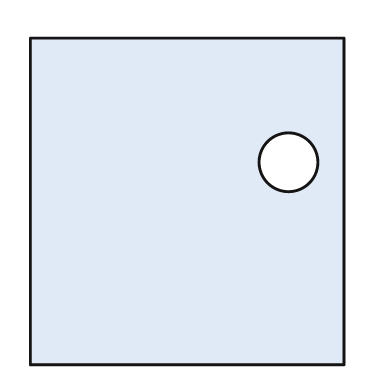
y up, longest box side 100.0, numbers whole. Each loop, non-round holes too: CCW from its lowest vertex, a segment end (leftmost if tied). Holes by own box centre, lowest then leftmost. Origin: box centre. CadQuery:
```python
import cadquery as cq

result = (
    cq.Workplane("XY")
    .moveTo(-48.0, -50.0)
    .lineTo(48.0, -50.0)
    .lineTo(48.0, 50.0)
    .lineTo(-48.0, 50.0)
    .close()
    .moveTo(31.0, 12.0)
    .circle(9.0)
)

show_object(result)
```